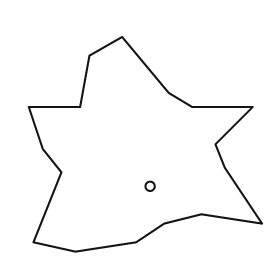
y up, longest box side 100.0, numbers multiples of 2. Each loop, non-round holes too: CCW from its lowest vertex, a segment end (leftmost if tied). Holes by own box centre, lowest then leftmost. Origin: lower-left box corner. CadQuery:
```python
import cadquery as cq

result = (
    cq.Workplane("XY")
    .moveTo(20.0, 0.0)
    .lineTo(46.0, 4.0)
    .lineTo(58.0, 12.0)
    .lineTo(74.0, 16.0)
    .lineTo(100.0, 12.0)
    .lineTo(84.0, 36.0)
    .lineTo(80.0, 46.0)
    .lineTo(96.0, 62.0)
    .lineTo(70.0, 62.0)
    .lineTo(60.0, 68.0)
    .lineTo(40.0, 92.0)
    .lineTo(26.0, 84.0)
    .lineTo(22.0, 62.0)
    .lineTo(0.0, 62.0)
    .lineTo(6.0, 44.0)
    .lineTo(14.0, 34.0)
    .lineTo(2.0, 4.0)
    .close()
    .moveTo(52.0, 28.0)
    .circle(2.0)
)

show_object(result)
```